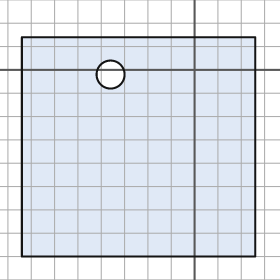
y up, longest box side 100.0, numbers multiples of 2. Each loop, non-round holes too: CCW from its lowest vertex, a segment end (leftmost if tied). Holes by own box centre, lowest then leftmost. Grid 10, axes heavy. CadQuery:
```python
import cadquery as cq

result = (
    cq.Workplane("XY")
    .moveTo(-74.0, -80.0)
    .lineTo(26.0, -80.0)
    .lineTo(26.0, 14.0)
    .lineTo(-74.0, 14.0)
    .close()
    .moveTo(-36.0, -2.0)
    .circle(6.0)
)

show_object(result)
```